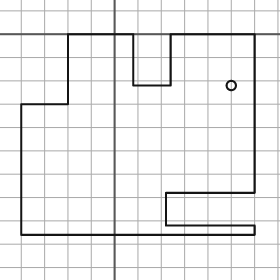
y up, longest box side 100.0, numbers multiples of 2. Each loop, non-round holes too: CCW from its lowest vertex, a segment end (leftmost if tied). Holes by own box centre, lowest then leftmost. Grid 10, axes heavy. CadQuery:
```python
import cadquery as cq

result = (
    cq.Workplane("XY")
    .moveTo(-40.0, -86.0)
    .lineTo(60.0, -86.0)
    .lineTo(60.0, -82.0)
    .lineTo(22.0, -82.0)
    .lineTo(22.0, -68.0)
    .lineTo(60.0, -68.0)
    .lineTo(60.0, 0.0)
    .lineTo(24.0, 0.0)
    .lineTo(24.0, -22.0)
    .lineTo(8.0, -22.0)
    .lineTo(8.0, 0.0)
    .lineTo(-20.0, 0.0)
    .lineTo(-20.0, -30.0)
    .lineTo(-40.0, -30.0)
    .close()
    .moveTo(50.0, -22.0)
    .circle(2.0)
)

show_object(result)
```